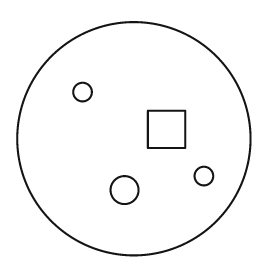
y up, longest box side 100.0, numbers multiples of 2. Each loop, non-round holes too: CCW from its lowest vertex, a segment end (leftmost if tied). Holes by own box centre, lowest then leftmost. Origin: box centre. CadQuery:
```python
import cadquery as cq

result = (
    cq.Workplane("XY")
    .moveTo(0.0, 0.0)
    .circle(50.0)
    .moveTo(-4.0, -22.0)
    .circle(6.0)
    .moveTo(30.0, -16.0)
    .circle(4.0)
    .moveTo(6.0, -4.0)
    .lineTo(22.0, -4.0)
    .lineTo(22.0, 12.0)
    .lineTo(6.0, 12.0)
    .close()
    .moveTo(-22.0, 20.0)
    .circle(4.0)
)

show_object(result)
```